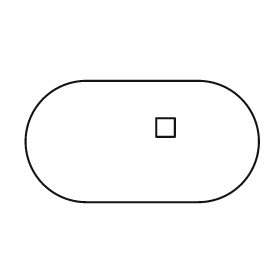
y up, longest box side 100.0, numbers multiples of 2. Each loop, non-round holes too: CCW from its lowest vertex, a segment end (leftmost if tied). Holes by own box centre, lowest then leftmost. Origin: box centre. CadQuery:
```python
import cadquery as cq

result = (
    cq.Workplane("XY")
    .moveTo(-24.0, -26.0)
    .lineTo(24.0, -26.0)
    .threePointArc((50.0, 0.0), (24.0, 26.0))
    .lineTo(-24.0, 26.0)
    .threePointArc((-50.0, 0.0), (-24.0, -26.0))
    .close()
    .moveTo(6.0, 2.0)
    .lineTo(14.0, 2.0)
    .lineTo(14.0, 10.0)
    .lineTo(6.0, 10.0)
    .close()
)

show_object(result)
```